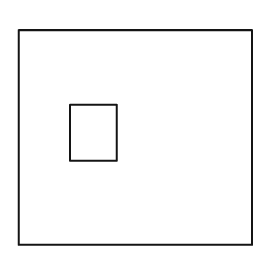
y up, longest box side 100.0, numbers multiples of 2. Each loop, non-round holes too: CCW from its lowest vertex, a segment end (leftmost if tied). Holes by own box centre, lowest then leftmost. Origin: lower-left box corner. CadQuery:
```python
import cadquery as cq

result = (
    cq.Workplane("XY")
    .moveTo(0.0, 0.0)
    .lineTo(100.0, 0.0)
    .lineTo(100.0, 92.0)
    .lineTo(0.0, 92.0)
    .close()
    .moveTo(22.0, 36.0)
    .lineTo(42.0, 36.0)
    .lineTo(42.0, 60.0)
    .lineTo(22.0, 60.0)
    .close()
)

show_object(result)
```